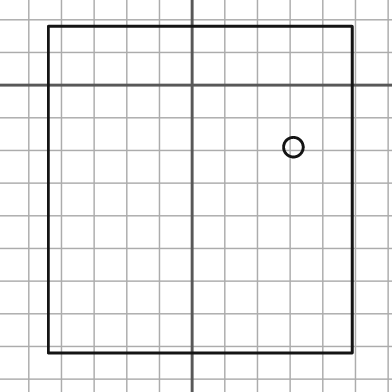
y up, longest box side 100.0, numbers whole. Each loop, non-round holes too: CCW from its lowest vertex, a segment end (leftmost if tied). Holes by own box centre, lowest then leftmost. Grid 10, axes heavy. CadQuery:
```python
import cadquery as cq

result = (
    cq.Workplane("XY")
    .moveTo(-44.0, -82.0)
    .lineTo(49.0, -82.0)
    .lineTo(49.0, 18.0)
    .lineTo(-44.0, 18.0)
    .close()
    .moveTo(31.0, -19.0)
    .circle(3.0)
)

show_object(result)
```